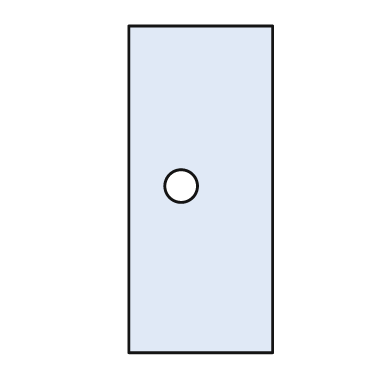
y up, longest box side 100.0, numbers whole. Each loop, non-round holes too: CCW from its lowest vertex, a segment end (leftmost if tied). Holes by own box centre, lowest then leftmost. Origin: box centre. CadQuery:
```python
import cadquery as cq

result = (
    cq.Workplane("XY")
    .moveTo(-22.0, -50.0)
    .lineTo(22.0, -50.0)
    .lineTo(22.0, 50.0)
    .lineTo(-22.0, 50.0)
    .close()
    .moveTo(-6.0, 1.0)
    .circle(5.0)
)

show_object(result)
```